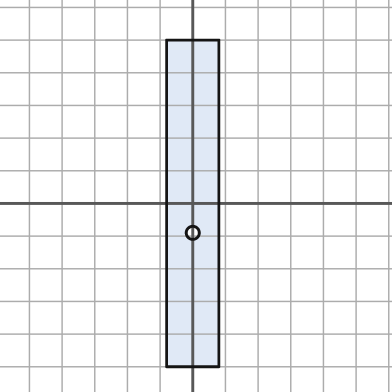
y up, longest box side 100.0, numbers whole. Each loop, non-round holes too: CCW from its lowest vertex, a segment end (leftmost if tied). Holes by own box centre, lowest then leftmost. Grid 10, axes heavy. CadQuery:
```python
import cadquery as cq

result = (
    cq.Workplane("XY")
    .moveTo(-8.0, -50.0)
    .lineTo(8.0, -50.0)
    .lineTo(8.0, 50.0)
    .lineTo(-8.0, 50.0)
    .close()
    .moveTo(0.0, -9.0)
    .circle(2.0)
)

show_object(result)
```